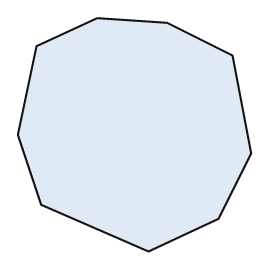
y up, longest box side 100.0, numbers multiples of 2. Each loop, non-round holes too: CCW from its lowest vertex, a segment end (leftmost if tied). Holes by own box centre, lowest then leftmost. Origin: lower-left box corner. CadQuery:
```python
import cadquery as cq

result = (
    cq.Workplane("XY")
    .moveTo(56.0, 0.0)
    .lineTo(86.0, 14.0)
    .lineTo(100.0, 42.0)
    .lineTo(92.0, 84.0)
    .lineTo(64.0, 98.0)
    .lineTo(34.0, 100.0)
    .lineTo(8.0, 88.0)
    .lineTo(0.0, 50.0)
    .lineTo(10.0, 20.0)
    .close()
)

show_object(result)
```